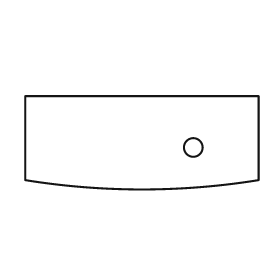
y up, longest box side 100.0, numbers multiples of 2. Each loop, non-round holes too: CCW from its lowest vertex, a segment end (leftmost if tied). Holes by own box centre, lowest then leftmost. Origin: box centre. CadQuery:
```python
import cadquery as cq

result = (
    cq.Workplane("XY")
    .moveTo(-50.0, -16.0)
    .threePointArc((0.0, -20.0), (50.0, -16.0))
    .lineTo(50.0, 20.0)
    .lineTo(-50.0, 20.0)
    .close()
    .moveTo(22.0, -2.0)
    .circle(4.0)
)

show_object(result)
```